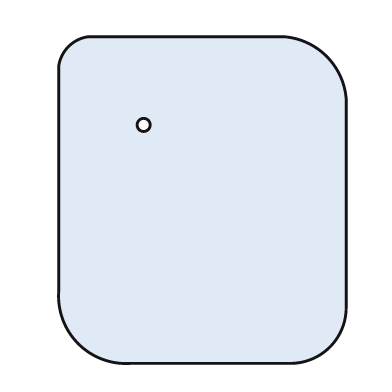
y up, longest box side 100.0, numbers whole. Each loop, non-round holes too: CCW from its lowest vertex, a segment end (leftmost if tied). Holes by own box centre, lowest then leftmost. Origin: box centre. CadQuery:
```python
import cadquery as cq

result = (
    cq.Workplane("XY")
    .moveTo(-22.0, -50.0)
    .lineTo(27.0, -50.0)
    .threePointArc((39.0, -45.0), (44.0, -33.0))
    .lineTo(44.0, 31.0)
    .threePointArc((38.0, 44.0), (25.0, 50.0))
    .lineTo(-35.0, 50.0)
    .threePointArc((-41.0, 47.0), (-44.0, 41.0))
    .lineTo(-44.0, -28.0)
    .threePointArc((-38.0, -44.0), (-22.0, -50.0))
    .close()
    .moveTo(-18.0, 23.0)
    .circle(2.0)
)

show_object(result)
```